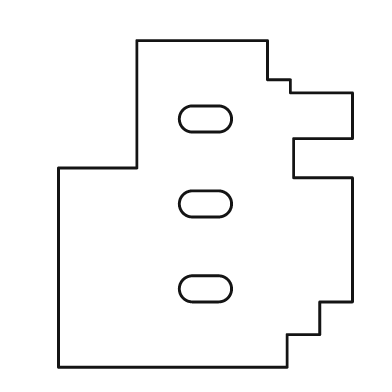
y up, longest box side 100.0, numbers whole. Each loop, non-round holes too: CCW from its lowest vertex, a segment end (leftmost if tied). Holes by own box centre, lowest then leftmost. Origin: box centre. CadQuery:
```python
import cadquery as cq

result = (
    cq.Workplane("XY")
    .moveTo(-45.0, -50.0)
    .lineTo(25.0, -50.0)
    .lineTo(25.0, -40.0)
    .lineTo(35.0, -40.0)
    .lineTo(35.0, -30.0)
    .lineTo(45.0, -30.0)
    .lineTo(45.0, 8.0)
    .lineTo(27.0, 8.0)
    .lineTo(27.0, 20.0)
    .lineTo(45.0, 20.0)
    .lineTo(45.0, 34.0)
    .lineTo(26.0, 34.0)
    .lineTo(26.0, 38.0)
    .lineTo(19.0, 38.0)
    .lineTo(19.0, 50.0)
    .lineTo(-21.0, 50.0)
    .lineTo(-21.0, 11.0)
    .lineTo(-45.0, 11.0)
    .close()
    .moveTo(-4.0, -30.0)
    .lineTo(4.0, -30.0)
    .threePointArc((8.0, -26.0), (4.0, -22.0))
    .lineTo(-4.0, -22.0)
    .threePointArc((-8.0, -26.0), (-4.0, -30.0))
    .close()
    .moveTo(-4.0, -4.0)
    .lineTo(4.0, -4.0)
    .threePointArc((8.0, 0.0), (4.0, 4.0))
    .lineTo(-4.0, 4.0)
    .threePointArc((-8.0, 0.0), (-4.0, -4.0))
    .close()
    .moveTo(-4.0, 22.0)
    .lineTo(4.0, 22.0)
    .threePointArc((8.0, 26.0), (4.0, 30.0))
    .lineTo(-4.0, 30.0)
    .threePointArc((-8.0, 26.0), (-4.0, 22.0))
    .close()
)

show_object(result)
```